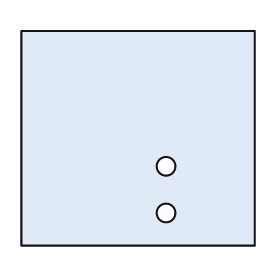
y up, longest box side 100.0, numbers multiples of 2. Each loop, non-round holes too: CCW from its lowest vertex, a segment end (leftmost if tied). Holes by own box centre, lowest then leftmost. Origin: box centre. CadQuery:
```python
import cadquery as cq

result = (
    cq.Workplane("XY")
    .moveTo(-50.0, -46.0)
    .lineTo(50.0, -46.0)
    .lineTo(50.0, 46.0)
    .lineTo(-50.0, 46.0)
    .close()
    .moveTo(12.0, -32.0)
    .circle(4.0)
    .moveTo(12.0, -12.0)
    .circle(4.0)
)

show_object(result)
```